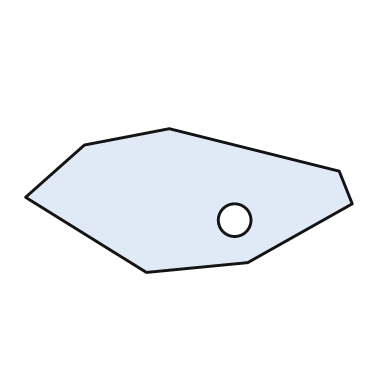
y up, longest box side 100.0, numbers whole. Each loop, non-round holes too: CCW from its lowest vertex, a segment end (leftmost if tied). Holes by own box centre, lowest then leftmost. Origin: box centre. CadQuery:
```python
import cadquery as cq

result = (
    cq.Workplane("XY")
    .moveTo(-13.0, -22.0)
    .lineTo(18.0, -19.0)
    .lineTo(50.0, -1.0)
    .lineTo(46.0, 9.0)
    .lineTo(-6.0, 22.0)
    .lineTo(-32.0, 17.0)
    .lineTo(-50.0, 1.0)
    .close()
    .moveTo(14.0, -6.0)
    .circle(5.0)
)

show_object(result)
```